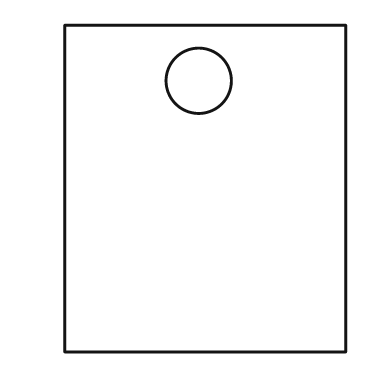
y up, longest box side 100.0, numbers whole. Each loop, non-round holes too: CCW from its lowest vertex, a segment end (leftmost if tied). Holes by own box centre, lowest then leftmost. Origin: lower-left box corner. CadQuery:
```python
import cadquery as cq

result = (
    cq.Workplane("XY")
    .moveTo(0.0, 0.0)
    .lineTo(86.0, 0.0)
    .lineTo(86.0, 100.0)
    .lineTo(0.0, 100.0)
    .close()
    .moveTo(41.0, 83.0)
    .circle(10.0)
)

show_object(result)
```